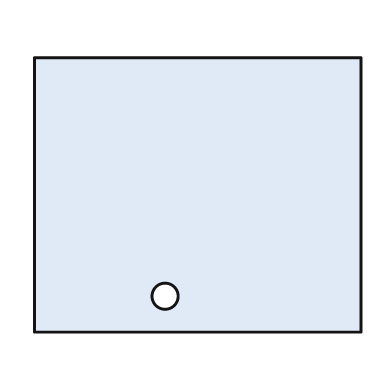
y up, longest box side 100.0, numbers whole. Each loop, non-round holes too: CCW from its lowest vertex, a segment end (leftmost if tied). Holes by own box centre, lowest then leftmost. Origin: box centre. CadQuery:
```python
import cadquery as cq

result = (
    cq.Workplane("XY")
    .moveTo(-50.0, -42.0)
    .lineTo(50.0, -42.0)
    .lineTo(50.0, 42.0)
    .lineTo(-50.0, 42.0)
    .close()
    .moveTo(-10.0, -31.0)
    .circle(4.0)
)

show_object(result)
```